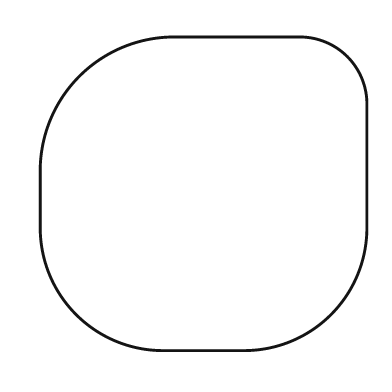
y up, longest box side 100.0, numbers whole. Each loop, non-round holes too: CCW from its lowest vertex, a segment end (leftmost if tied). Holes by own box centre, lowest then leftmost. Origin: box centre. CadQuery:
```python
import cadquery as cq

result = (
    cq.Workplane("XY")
    .moveTo(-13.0, -48.0)
    .lineTo(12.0, -48.0)
    .threePointArc((39.0, -37.0), (50.0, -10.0))
    .lineTo(50.0, 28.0)
    .threePointArc((44.0, 42.0), (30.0, 48.0))
    .lineTo(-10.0, 48.0)
    .threePointArc((-38.0, 36.0), (-50.0, 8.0))
    .lineTo(-50.0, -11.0)
    .threePointArc((-39.0, -37.0), (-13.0, -48.0))
    .close()
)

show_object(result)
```